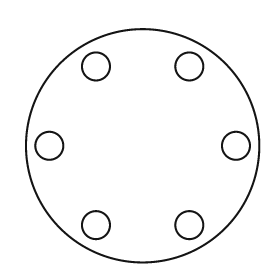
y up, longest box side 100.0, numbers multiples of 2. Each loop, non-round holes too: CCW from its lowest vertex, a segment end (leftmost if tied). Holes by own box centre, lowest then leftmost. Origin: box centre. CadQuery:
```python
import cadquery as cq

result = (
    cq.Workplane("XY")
    .moveTo(0.0, 0.0)
    .circle(50.0)
    .moveTo(-20.0, -34.0)
    .circle(6.0)
    .moveTo(20.0, -34.0)
    .circle(6.0)
    .moveTo(-40.0, 0.0)
    .circle(6.0)
    .moveTo(40.0, 0.0)
    .circle(6.0)
    .moveTo(-20.0, 34.0)
    .circle(6.0)
    .moveTo(20.0, 34.0)
    .circle(6.0)
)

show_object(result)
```